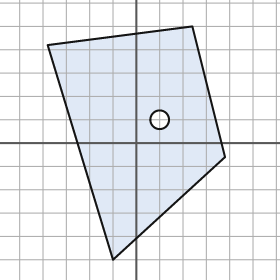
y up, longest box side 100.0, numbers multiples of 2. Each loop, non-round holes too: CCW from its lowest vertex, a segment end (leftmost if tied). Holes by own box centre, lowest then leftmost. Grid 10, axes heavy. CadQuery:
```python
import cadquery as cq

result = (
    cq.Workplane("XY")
    .moveTo(-10.0, -50.0)
    .lineTo(38.0, -6.0)
    .lineTo(24.0, 50.0)
    .lineTo(-38.0, 42.0)
    .close()
    .moveTo(10.0, 10.0)
    .circle(4.0)
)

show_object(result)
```